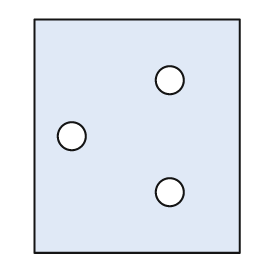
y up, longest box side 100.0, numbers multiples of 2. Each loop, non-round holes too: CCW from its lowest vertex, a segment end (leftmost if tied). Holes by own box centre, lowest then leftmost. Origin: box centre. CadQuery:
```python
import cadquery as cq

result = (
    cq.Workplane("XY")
    .moveTo(-44.0, -50.0)
    .lineTo(44.0, -50.0)
    .lineTo(44.0, 50.0)
    .lineTo(-44.0, 50.0)
    .close()
    .moveTo(14.0, -24.0)
    .circle(6.0)
    .moveTo(-28.0, 0.0)
    .circle(6.0)
    .moveTo(14.0, 24.0)
    .circle(6.0)
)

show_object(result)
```